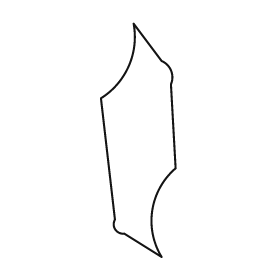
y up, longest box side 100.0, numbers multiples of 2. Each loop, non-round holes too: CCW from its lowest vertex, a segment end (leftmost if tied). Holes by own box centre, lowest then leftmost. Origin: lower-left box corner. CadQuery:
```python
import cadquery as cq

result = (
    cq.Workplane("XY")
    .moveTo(26.0, 0.0)
    .threePointArc((22.0, 20.0), (32.0, 38.0))
    .lineTo(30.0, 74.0)
    .threePointArc((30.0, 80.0), (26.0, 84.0))
    .lineTo(14.0, 100.0)
    .threePointArc((12.0, 82.0), (0.0, 68.0))
    .lineTo(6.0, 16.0)
    .threePointArc((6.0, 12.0), (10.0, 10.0))
    .close()
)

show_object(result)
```